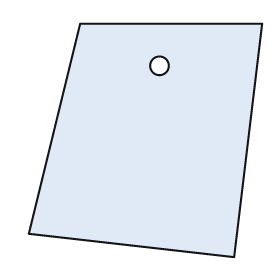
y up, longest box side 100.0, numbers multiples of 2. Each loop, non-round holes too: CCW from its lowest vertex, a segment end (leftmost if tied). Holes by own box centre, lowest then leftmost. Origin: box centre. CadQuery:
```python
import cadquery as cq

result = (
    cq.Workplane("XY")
    .moveTo(38.0, -50.0)
    .lineTo(50.0, 50.0)
    .lineTo(-28.0, 50.0)
    .lineTo(-50.0, -40.0)
    .close()
    .moveTo(6.0, 32.0)
    .circle(4.0)
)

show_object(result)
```